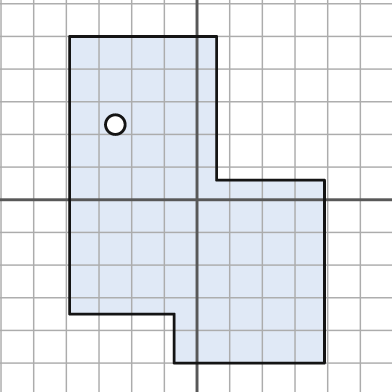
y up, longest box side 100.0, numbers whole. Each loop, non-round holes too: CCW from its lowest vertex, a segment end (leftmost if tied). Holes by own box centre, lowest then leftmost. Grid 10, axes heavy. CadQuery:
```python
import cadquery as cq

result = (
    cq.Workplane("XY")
    .moveTo(-7.0, -50.0)
    .lineTo(39.0, -50.0)
    .lineTo(39.0, 6.0)
    .lineTo(6.0, 6.0)
    .lineTo(6.0, 50.0)
    .lineTo(-39.0, 50.0)
    .lineTo(-39.0, -35.0)
    .lineTo(-7.0, -35.0)
    .close()
    .moveTo(-25.0, 23.0)
    .circle(3.0)
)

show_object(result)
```